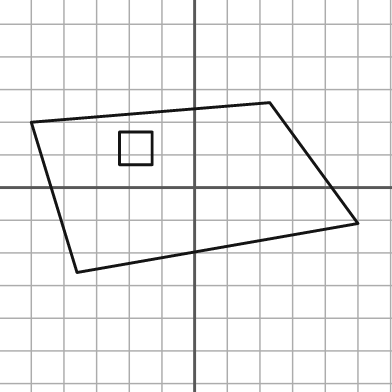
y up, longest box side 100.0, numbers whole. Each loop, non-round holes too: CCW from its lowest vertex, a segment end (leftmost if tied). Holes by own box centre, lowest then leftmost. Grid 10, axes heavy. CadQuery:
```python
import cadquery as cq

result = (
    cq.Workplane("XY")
    .moveTo(-36.0, -26.0)
    .lineTo(50.0, -11.0)
    .lineTo(23.0, 26.0)
    .lineTo(-50.0, 20.0)
    .close()
    .moveTo(-23.0, 7.0)
    .lineTo(-13.0, 7.0)
    .lineTo(-13.0, 17.0)
    .lineTo(-23.0, 17.0)
    .close()
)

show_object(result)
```